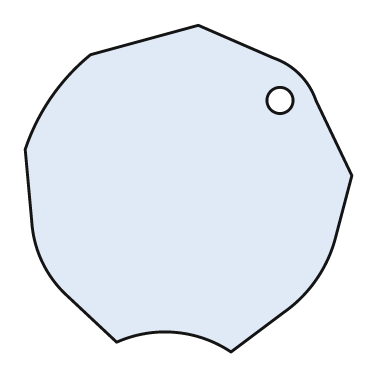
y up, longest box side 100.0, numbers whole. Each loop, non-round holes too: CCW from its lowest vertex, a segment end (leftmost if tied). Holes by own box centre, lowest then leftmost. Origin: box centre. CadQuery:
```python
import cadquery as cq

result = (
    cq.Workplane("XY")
    .moveTo(13.0, -50.0)
    .lineTo(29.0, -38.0)
    .threePointArc((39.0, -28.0), (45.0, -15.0))
    .lineTo(50.0, 4.0)
    .lineTo(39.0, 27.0)
    .threePointArc((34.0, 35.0), (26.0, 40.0))
    .lineTo(3.0, 50.0)
    .lineTo(-30.0, 41.0)
    .threePointArc((-42.0, 28.0), (-50.0, 12.0))
    .lineTo(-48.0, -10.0)
    .threePointArc((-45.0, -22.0), (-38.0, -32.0))
    .lineTo(-22.0, -47.0)
    .threePointArc((-4.0, -44.0), (13.0, -50.0))
    .close()
    .moveTo(28.0, 27.0)
    .circle(4.0)
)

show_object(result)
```